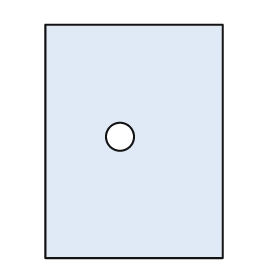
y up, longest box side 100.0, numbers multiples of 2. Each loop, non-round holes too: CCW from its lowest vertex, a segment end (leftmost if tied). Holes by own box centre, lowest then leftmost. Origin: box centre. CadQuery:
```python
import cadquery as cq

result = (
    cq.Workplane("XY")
    .moveTo(-38.0, -50.0)
    .lineTo(38.0, -50.0)
    .lineTo(38.0, 50.0)
    .lineTo(-38.0, 50.0)
    .close()
    .moveTo(-6.0, 2.0)
    .circle(6.0)
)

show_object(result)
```